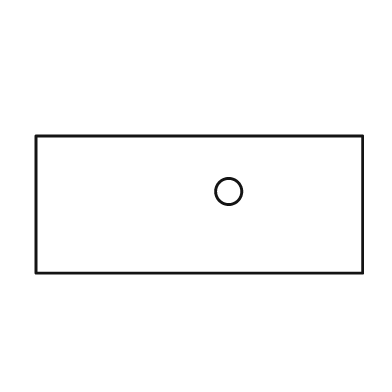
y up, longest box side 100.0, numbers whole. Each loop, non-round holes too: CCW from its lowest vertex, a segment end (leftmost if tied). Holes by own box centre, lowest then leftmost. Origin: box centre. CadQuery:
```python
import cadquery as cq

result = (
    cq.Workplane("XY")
    .moveTo(-50.0, -21.0)
    .lineTo(50.0, -21.0)
    .lineTo(50.0, 21.0)
    .lineTo(-50.0, 21.0)
    .close()
    .moveTo(9.0, 4.0)
    .circle(4.0)
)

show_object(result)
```